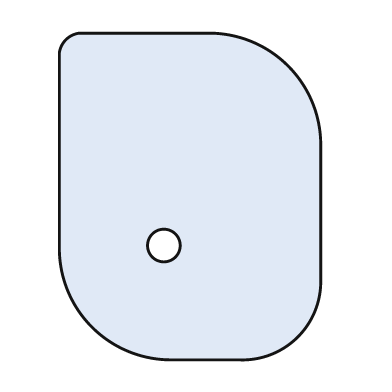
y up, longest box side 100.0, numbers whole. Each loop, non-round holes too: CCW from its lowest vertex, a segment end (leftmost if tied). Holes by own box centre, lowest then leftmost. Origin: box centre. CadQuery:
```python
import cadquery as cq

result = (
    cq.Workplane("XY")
    .moveTo(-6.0, -50.0)
    .lineTo(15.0, -50.0)
    .threePointArc((33.0, -43.0), (40.0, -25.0))
    .lineTo(40.0, 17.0)
    .threePointArc((30.0, 40.0), (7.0, 50.0))
    .lineTo(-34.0, 50.0)
    .threePointArc((-38.0, 48.0), (-40.0, 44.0))
    .lineTo(-40.0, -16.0)
    .threePointArc((-30.0, -40.0), (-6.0, -50.0))
    .close()
    .moveTo(-8.0, -15.0)
    .circle(5.0)
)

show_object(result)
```